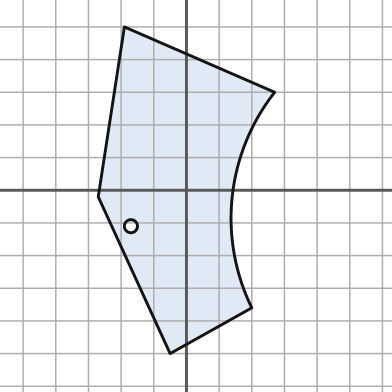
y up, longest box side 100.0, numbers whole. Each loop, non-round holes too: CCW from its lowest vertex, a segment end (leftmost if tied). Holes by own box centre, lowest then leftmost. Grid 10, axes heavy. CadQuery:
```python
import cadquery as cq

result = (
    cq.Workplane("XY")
    .moveTo(-5.0, -50.0)
    .lineTo(20.0, -36.0)
    .threePointArc((14.0, -2.0), (27.0, 30.0))
    .lineTo(-19.0, 50.0)
    .lineTo(-27.0, -2.0)
    .close()
    .moveTo(-17.0, -11.0)
    .circle(2.0)
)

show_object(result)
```